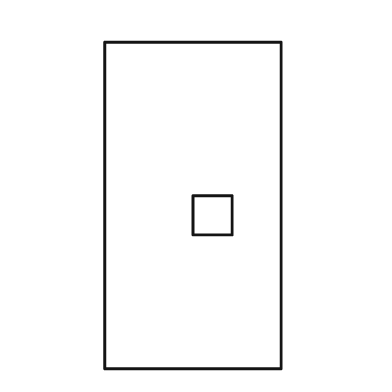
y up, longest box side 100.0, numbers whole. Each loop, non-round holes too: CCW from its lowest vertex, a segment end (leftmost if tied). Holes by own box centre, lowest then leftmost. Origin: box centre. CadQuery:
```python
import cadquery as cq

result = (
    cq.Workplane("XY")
    .moveTo(-27.0, -50.0)
    .lineTo(27.0, -50.0)
    .lineTo(27.0, 50.0)
    .lineTo(-27.0, 50.0)
    .close()
    .moveTo(0.0, -9.0)
    .lineTo(12.0, -9.0)
    .lineTo(12.0, 3.0)
    .lineTo(0.0, 3.0)
    .close()
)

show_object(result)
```